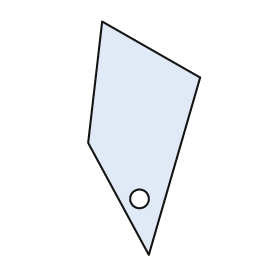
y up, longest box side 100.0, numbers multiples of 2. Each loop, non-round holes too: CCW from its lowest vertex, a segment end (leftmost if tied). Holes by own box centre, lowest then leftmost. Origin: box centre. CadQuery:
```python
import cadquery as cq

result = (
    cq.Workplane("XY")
    .moveTo(2.0, -50.0)
    .lineTo(24.0, 26.0)
    .lineTo(-18.0, 50.0)
    .lineTo(-24.0, -2.0)
    .close()
    .moveTo(-2.0, -26.0)
    .circle(4.0)
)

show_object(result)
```